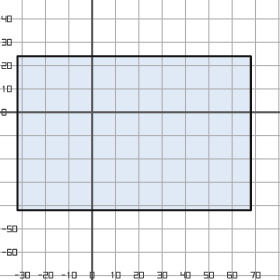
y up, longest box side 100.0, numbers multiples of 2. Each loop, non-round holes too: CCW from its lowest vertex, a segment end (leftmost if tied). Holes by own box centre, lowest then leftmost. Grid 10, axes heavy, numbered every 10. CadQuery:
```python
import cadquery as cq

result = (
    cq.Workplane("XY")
    .moveTo(-32.0, -42.0)
    .lineTo(68.0, -42.0)
    .lineTo(68.0, 24.0)
    .lineTo(-32.0, 24.0)
    .close()
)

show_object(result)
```